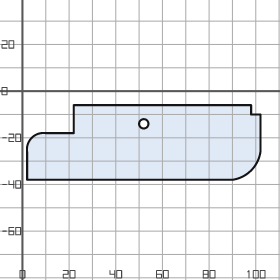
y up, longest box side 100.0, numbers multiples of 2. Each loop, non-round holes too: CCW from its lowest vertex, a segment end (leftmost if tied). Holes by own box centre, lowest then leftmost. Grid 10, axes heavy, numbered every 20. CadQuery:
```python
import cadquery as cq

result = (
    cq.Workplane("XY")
    .moveTo(2.0, -38.0)
    .lineTo(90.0, -38.0)
    .threePointArc((98.0, -34.0), (102.0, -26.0))
    .lineTo(102.0, -10.0)
    .lineTo(98.0, -10.0)
    .lineTo(98.0, -6.0)
    .lineTo(22.0, -6.0)
    .lineTo(22.0, -18.0)
    .lineTo(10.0, -18.0)
    .threePointArc((4.0, -20.0), (2.0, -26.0))
    .close()
    .moveTo(52.0, -14.0)
    .circle(2.0)
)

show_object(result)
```